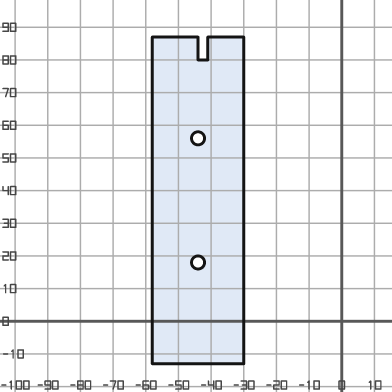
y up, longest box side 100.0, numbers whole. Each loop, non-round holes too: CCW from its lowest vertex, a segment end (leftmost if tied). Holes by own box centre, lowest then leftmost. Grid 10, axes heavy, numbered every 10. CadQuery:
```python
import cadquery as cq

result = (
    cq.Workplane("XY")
    .moveTo(-58.0, -13.0)
    .lineTo(-30.0, -13.0)
    .lineTo(-30.0, 87.0)
    .lineTo(-41.0, 87.0)
    .lineTo(-41.0, 80.0)
    .lineTo(-44.0, 80.0)
    .lineTo(-44.0, 87.0)
    .lineTo(-58.0, 87.0)
    .close()
    .moveTo(-44.0, 18.0)
    .circle(2.0)
    .moveTo(-44.0, 56.0)
    .circle(2.0)
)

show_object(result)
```